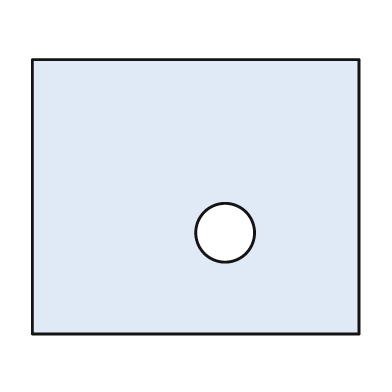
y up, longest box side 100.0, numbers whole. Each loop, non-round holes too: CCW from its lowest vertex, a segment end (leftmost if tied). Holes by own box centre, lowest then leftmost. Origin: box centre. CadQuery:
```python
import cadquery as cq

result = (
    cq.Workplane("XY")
    .moveTo(-50.0, -42.0)
    .lineTo(50.0, -42.0)
    .lineTo(50.0, 42.0)
    .lineTo(-50.0, 42.0)
    .close()
    .moveTo(9.0, -11.0)
    .circle(9.0)
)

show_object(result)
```